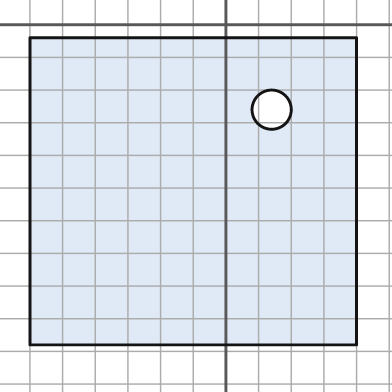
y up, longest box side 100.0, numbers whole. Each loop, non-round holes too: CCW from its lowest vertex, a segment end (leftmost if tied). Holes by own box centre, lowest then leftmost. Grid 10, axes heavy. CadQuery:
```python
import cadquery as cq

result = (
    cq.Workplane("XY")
    .moveTo(-60.0, -98.0)
    .lineTo(40.0, -98.0)
    .lineTo(40.0, -4.0)
    .lineTo(-60.0, -4.0)
    .close()
    .moveTo(14.0, -26.0)
    .circle(6.0)
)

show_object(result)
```